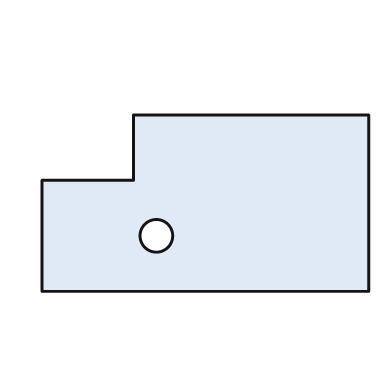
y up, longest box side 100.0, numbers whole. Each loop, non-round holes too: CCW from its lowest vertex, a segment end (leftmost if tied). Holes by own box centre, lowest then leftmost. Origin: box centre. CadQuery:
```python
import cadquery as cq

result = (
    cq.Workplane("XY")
    .moveTo(-50.0, -27.0)
    .lineTo(50.0, -27.0)
    .lineTo(50.0, 27.0)
    .lineTo(-22.0, 27.0)
    .lineTo(-22.0, 7.0)
    .lineTo(-50.0, 7.0)
    .close()
    .moveTo(-15.0, -10.0)
    .circle(5.0)
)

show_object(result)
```